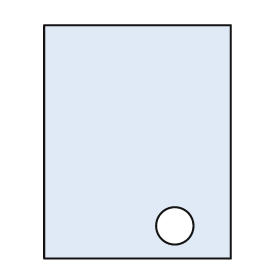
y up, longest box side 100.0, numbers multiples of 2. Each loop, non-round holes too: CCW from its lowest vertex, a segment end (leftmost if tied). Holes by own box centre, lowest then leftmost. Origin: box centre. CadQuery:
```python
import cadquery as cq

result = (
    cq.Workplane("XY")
    .moveTo(-40.0, -50.0)
    .lineTo(40.0, -50.0)
    .lineTo(40.0, 50.0)
    .lineTo(-40.0, 50.0)
    .close()
    .moveTo(16.0, -36.0)
    .circle(8.0)
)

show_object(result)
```